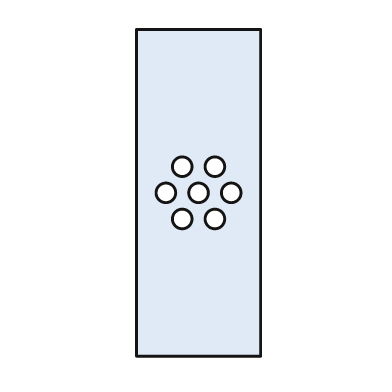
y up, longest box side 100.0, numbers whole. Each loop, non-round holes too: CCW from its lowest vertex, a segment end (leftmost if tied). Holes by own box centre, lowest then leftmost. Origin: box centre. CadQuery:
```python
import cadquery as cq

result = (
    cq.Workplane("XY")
    .moveTo(-19.0, -50.0)
    .lineTo(19.0, -50.0)
    .lineTo(19.0, 50.0)
    .lineTo(-19.0, 50.0)
    .close()
    .moveTo(-5.0, -8.0)
    .circle(3.0)
    .moveTo(5.0, -8.0)
    .circle(3.0)
    .moveTo(-10.0, 0.0)
    .circle(3.0)
    .moveTo(0.0, 0.0)
    .circle(3.0)
    .moveTo(10.0, 0.0)
    .circle(3.0)
    .moveTo(-5.0, 8.0)
    .circle(3.0)
    .moveTo(5.0, 8.0)
    .circle(3.0)
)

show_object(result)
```